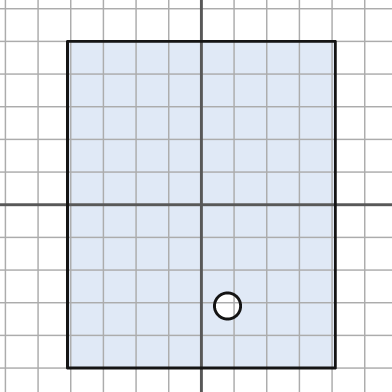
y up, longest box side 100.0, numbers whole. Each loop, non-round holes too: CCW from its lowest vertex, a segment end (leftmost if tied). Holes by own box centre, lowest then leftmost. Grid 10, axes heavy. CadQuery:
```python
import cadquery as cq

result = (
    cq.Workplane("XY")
    .moveTo(-41.0, -50.0)
    .lineTo(41.0, -50.0)
    .lineTo(41.0, 50.0)
    .lineTo(-41.0, 50.0)
    .close()
    .moveTo(8.0, -31.0)
    .circle(4.0)
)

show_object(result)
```